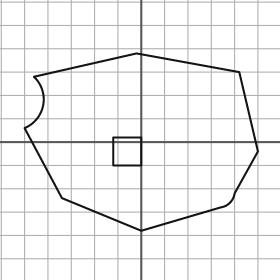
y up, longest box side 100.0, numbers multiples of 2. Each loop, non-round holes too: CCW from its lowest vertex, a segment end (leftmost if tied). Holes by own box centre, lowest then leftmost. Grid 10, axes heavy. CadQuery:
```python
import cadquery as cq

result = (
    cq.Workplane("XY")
    .moveTo(0.0, -38.0)
    .lineTo(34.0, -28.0)
    .threePointArc((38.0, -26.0), (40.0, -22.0))
    .lineTo(50.0, -4.0)
    .lineTo(42.0, 30.0)
    .lineTo(-2.0, 38.0)
    .lineTo(-46.0, 28.0)
    .threePointArc((-42.0, 16.0), (-50.0, 6.0))
    .lineTo(-34.0, -24.0)
    .close()
    .moveTo(-12.0, -10.0)
    .lineTo(0.0, -10.0)
    .lineTo(0.0, 2.0)
    .lineTo(-12.0, 2.0)
    .close()
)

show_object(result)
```